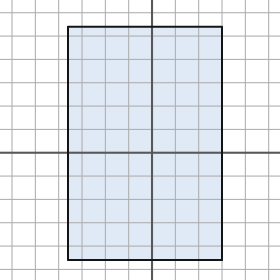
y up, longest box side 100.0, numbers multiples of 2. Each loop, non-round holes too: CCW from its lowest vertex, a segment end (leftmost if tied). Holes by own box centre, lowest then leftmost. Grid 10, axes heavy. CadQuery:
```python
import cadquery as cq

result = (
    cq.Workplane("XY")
    .moveTo(-36.0, -46.0)
    .lineTo(30.0, -46.0)
    .lineTo(30.0, 54.0)
    .lineTo(-36.0, 54.0)
    .close()
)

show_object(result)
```